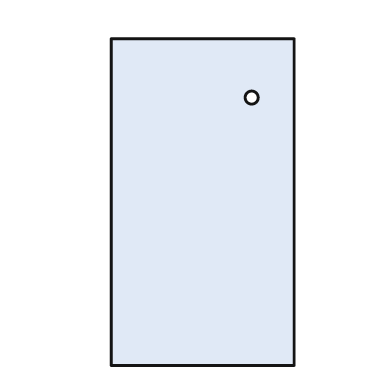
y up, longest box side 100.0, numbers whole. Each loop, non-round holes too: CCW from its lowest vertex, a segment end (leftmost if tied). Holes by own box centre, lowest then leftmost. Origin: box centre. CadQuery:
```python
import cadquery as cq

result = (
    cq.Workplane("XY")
    .moveTo(-28.0, -50.0)
    .lineTo(28.0, -50.0)
    .lineTo(28.0, 50.0)
    .lineTo(-28.0, 50.0)
    .close()
    .moveTo(15.0, 32.0)
    .circle(2.0)
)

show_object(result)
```